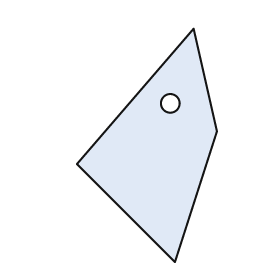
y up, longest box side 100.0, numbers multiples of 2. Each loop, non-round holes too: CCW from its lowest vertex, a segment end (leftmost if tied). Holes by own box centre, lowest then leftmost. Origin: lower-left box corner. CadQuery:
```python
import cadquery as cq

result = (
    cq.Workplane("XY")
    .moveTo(42.0, 0.0)
    .lineTo(60.0, 56.0)
    .lineTo(50.0, 100.0)
    .lineTo(0.0, 42.0)
    .close()
    .moveTo(40.0, 68.0)
    .circle(4.0)
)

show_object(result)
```